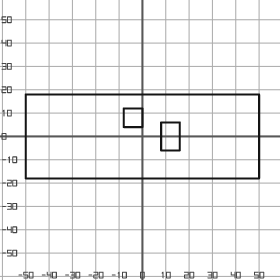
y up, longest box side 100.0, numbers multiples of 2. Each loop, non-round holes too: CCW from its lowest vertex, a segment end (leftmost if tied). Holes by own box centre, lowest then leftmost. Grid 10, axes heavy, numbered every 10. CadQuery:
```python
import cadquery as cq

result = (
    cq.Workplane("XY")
    .moveTo(-50.0, -18.0)
    .lineTo(50.0, -18.0)
    .lineTo(50.0, 18.0)
    .lineTo(-50.0, 18.0)
    .close()
    .moveTo(8.0, -6.0)
    .lineTo(16.0, -6.0)
    .lineTo(16.0, 6.0)
    .lineTo(8.0, 6.0)
    .close()
    .moveTo(-8.0, 4.0)
    .lineTo(0.0, 4.0)
    .lineTo(0.0, 12.0)
    .lineTo(-8.0, 12.0)
    .close()
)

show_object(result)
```